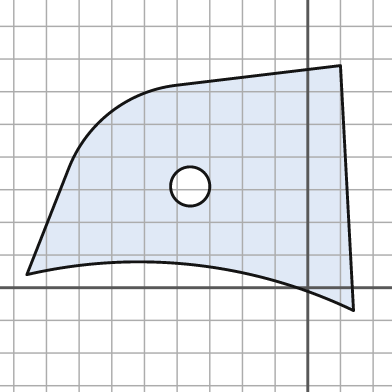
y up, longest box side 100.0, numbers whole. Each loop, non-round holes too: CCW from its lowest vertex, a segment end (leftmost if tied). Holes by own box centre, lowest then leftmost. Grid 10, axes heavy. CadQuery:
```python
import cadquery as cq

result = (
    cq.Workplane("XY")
    .moveTo(14.0, -7.0)
    .lineTo(10.0, 68.0)
    .lineTo(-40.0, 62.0)
    .threePointArc((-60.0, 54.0), (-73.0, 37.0))
    .lineTo(-86.0, 4.0)
    .threePointArc((-35.0, 7.0), (14.0, -7.0))
    .close()
    .moveTo(-36.0, 31.0)
    .circle(6.0)
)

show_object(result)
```